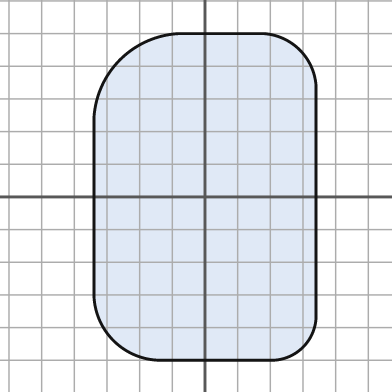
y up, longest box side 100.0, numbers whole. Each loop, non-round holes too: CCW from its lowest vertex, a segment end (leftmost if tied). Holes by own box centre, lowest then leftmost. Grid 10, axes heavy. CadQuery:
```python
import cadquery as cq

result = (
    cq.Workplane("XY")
    .moveTo(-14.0, -50.0)
    .lineTo(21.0, -50.0)
    .threePointArc((30.0, -46.0), (34.0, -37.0))
    .lineTo(34.0, 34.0)
    .threePointArc((29.0, 45.0), (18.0, 50.0))
    .lineTo(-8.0, 50.0)
    .threePointArc((-26.0, 42.0), (-34.0, 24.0))
    .lineTo(-34.0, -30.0)
    .threePointArc((-28.0, -44.0), (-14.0, -50.0))
    .close()
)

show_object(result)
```